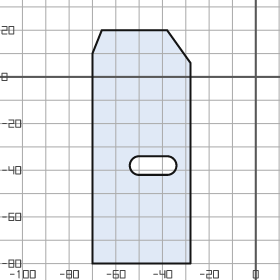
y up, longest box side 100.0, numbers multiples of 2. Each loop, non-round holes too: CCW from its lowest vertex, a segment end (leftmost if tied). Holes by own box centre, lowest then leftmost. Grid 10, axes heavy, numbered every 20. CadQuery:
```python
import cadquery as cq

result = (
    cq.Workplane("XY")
    .moveTo(-70.0, -80.0)
    .lineTo(-28.0, -80.0)
    .lineTo(-28.0, 6.0)
    .lineTo(-38.0, 20.0)
    .lineTo(-66.0, 20.0)
    .lineTo(-70.0, 10.0)
    .close()
    .moveTo(-50.0, -42.0)
    .lineTo(-38.0, -42.0)
    .threePointArc((-34.0, -38.0), (-38.0, -34.0))
    .lineTo(-50.0, -34.0)
    .threePointArc((-54.0, -38.0), (-50.0, -42.0))
    .close()
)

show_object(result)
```